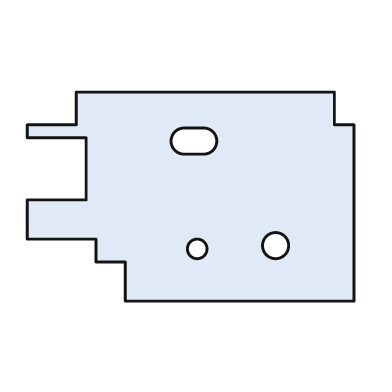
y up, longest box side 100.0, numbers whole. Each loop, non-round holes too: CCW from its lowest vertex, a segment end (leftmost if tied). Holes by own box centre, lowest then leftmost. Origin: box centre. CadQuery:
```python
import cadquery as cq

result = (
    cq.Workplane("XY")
    .moveTo(-20.0, -32.0)
    .lineTo(50.0, -32.0)
    .lineTo(50.0, 22.0)
    .lineTo(44.0, 22.0)
    .lineTo(44.0, 32.0)
    .lineTo(-35.0, 32.0)
    .lineTo(-35.0, 22.0)
    .lineTo(-50.0, 22.0)
    .lineTo(-50.0, 18.0)
    .lineTo(-32.0, 18.0)
    .lineTo(-32.0, -1.0)
    .lineTo(-50.0, -1.0)
    .lineTo(-50.0, -13.0)
    .lineTo(-29.0, -13.0)
    .lineTo(-29.0, -20.0)
    .lineTo(-20.0, -20.0)
    .close()
    .moveTo(2.0, -16.0)
    .circle(3.0)
    .moveTo(26.0, -15.0)
    .circle(4.0)
    .moveTo(-2.0, 13.0)
    .lineTo(4.0, 13.0)
    .threePointArc((8.0, 17.0), (4.0, 21.0))
    .lineTo(-2.0, 21.0)
    .threePointArc((-6.0, 17.0), (-2.0, 13.0))
    .close()
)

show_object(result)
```